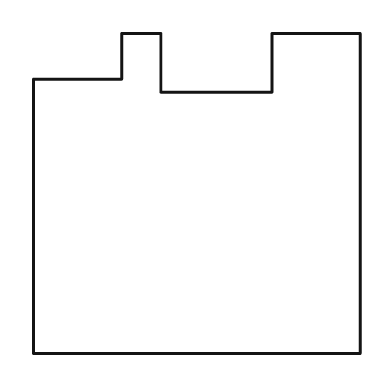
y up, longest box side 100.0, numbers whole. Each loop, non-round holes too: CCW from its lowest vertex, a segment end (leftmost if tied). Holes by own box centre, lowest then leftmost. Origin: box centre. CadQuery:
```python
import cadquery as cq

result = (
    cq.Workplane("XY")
    .moveTo(-50.0, -49.0)
    .lineTo(50.0, -49.0)
    .lineTo(50.0, 49.0)
    .lineTo(23.0, 49.0)
    .lineTo(23.0, 31.0)
    .lineTo(-11.0, 31.0)
    .lineTo(-11.0, 49.0)
    .lineTo(-23.0, 49.0)
    .lineTo(-23.0, 35.0)
    .lineTo(-50.0, 35.0)
    .close()
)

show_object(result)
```